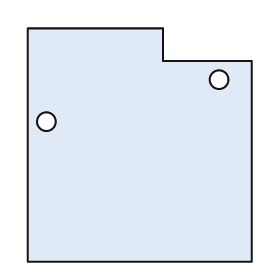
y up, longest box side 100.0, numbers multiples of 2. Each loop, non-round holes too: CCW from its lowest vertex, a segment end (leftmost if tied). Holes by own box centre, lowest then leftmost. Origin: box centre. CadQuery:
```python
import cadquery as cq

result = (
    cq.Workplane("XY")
    .moveTo(-48.0, -50.0)
    .lineTo(48.0, -50.0)
    .lineTo(48.0, 36.0)
    .lineTo(10.0, 36.0)
    .lineTo(10.0, 50.0)
    .lineTo(-48.0, 50.0)
    .close()
    .moveTo(-40.0, 10.0)
    .circle(4.0)
    .moveTo(34.0, 28.0)
    .circle(4.0)
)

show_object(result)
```